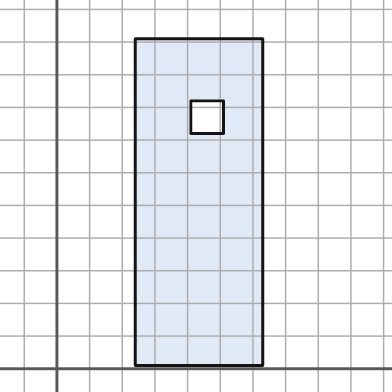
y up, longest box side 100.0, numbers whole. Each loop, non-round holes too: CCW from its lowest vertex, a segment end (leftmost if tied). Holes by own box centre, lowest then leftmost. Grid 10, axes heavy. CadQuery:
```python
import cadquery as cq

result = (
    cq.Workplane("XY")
    .moveTo(24.0, 1.0)
    .lineTo(63.0, 1.0)
    .lineTo(63.0, 101.0)
    .lineTo(24.0, 101.0)
    .close()
    .moveTo(41.0, 72.0)
    .lineTo(51.0, 72.0)
    .lineTo(51.0, 82.0)
    .lineTo(41.0, 82.0)
    .close()
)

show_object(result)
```